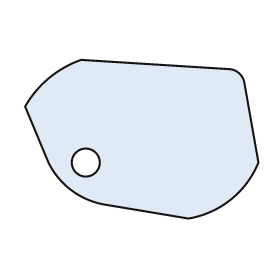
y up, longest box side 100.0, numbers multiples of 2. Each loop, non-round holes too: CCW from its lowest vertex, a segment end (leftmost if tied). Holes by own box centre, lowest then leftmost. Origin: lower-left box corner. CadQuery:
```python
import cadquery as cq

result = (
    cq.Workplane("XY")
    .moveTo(70.0, 0.0)
    .threePointArc((88.0, 8.0), (100.0, 24.0))
    .lineTo(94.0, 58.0)
    .threePointArc((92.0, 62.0), (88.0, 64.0))
    .lineTo(24.0, 68.0)
    .threePointArc((10.0, 60.0), (0.0, 48.0))
    .lineTo(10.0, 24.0)
    .threePointArc((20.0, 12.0), (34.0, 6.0))
    .close()
    .moveTo(26.0, 24.0)
    .circle(6.0)
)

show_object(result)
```